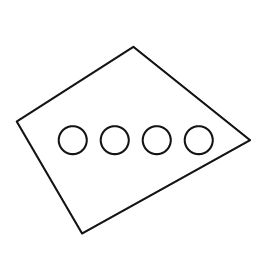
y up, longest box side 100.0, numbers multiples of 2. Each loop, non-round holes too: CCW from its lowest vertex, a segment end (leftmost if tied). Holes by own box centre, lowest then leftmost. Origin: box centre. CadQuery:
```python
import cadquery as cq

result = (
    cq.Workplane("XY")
    .moveTo(-22.0, -40.0)
    .lineTo(50.0, 0.0)
    .lineTo(0.0, 40.0)
    .lineTo(-50.0, 8.0)
    .close()
    .moveTo(-26.0, 0.0)
    .circle(6.0)
    .moveTo(-8.0, 0.0)
    .circle(6.0)
    .moveTo(10.0, 0.0)
    .circle(6.0)
    .moveTo(28.0, 0.0)
    .circle(6.0)
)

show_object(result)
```